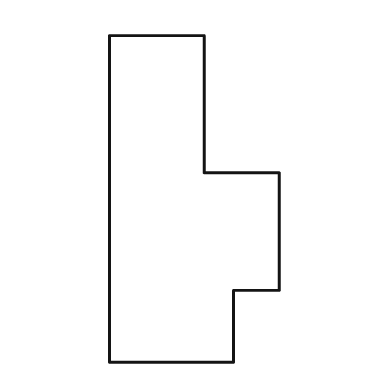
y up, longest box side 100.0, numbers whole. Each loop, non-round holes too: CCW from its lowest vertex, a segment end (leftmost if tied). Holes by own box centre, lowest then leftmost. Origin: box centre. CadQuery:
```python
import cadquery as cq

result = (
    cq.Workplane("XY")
    .moveTo(-26.0, -50.0)
    .lineTo(12.0, -50.0)
    .lineTo(12.0, -28.0)
    .lineTo(26.0, -28.0)
    .lineTo(26.0, 8.0)
    .lineTo(3.0, 8.0)
    .lineTo(3.0, 50.0)
    .lineTo(-26.0, 50.0)
    .close()
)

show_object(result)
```